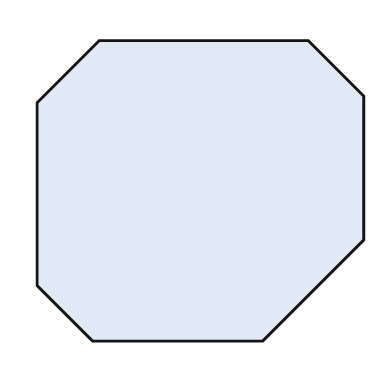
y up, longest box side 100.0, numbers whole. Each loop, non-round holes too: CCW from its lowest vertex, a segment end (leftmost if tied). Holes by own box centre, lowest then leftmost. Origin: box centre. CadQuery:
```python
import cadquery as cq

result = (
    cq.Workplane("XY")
    .moveTo(-33.0, -46.0)
    .lineTo(19.0, -46.0)
    .lineTo(50.0, -15.0)
    .lineTo(50.0, 29.0)
    .lineTo(33.0, 46.0)
    .lineTo(-31.0, 46.0)
    .lineTo(-50.0, 27.0)
    .lineTo(-50.0, -29.0)
    .close()
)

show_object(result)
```